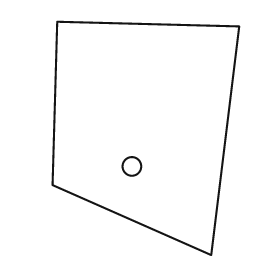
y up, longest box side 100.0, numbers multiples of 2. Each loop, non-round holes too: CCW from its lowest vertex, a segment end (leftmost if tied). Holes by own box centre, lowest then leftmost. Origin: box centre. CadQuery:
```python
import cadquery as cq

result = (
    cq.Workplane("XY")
    .moveTo(28.0, -50.0)
    .lineTo(40.0, 48.0)
    .lineTo(-38.0, 50.0)
    .lineTo(-40.0, -20.0)
    .close()
    .moveTo(-6.0, -12.0)
    .circle(4.0)
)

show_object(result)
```